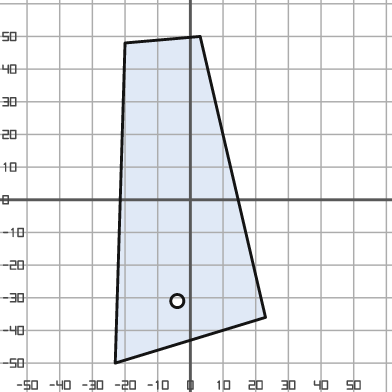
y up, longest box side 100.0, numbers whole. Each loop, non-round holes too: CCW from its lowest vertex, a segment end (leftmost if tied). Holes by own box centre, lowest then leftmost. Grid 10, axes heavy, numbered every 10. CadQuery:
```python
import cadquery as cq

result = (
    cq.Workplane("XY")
    .moveTo(-23.0, -50.0)
    .lineTo(23.0, -36.0)
    .lineTo(3.0, 50.0)
    .lineTo(-20.0, 48.0)
    .close()
    .moveTo(-4.0, -31.0)
    .circle(2.0)
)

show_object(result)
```